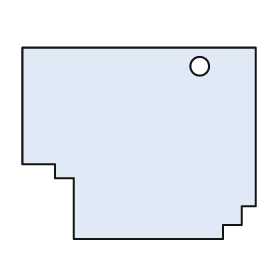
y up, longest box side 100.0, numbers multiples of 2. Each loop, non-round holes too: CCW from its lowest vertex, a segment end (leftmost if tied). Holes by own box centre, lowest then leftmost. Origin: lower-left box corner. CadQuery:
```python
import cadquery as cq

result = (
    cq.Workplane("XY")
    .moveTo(22.0, 0.0)
    .lineTo(86.0, 0.0)
    .lineTo(86.0, 6.0)
    .lineTo(94.0, 6.0)
    .lineTo(94.0, 14.0)
    .lineTo(100.0, 14.0)
    .lineTo(100.0, 82.0)
    .lineTo(0.0, 82.0)
    .lineTo(0.0, 32.0)
    .lineTo(14.0, 32.0)
    .lineTo(14.0, 26.0)
    .lineTo(22.0, 26.0)
    .close()
    .moveTo(76.0, 74.0)
    .circle(4.0)
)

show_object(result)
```